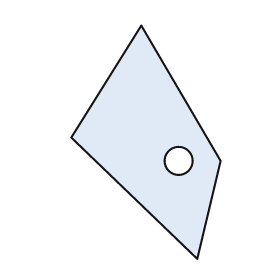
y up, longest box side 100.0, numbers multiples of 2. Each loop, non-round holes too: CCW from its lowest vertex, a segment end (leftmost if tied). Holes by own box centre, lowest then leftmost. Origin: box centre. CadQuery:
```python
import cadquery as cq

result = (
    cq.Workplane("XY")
    .moveTo(22.0, -50.0)
    .lineTo(32.0, -8.0)
    .lineTo(-2.0, 50.0)
    .lineTo(-32.0, 2.0)
    .close()
    .moveTo(14.0, -8.0)
    .circle(6.0)
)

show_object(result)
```